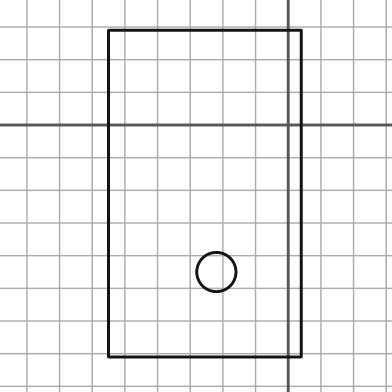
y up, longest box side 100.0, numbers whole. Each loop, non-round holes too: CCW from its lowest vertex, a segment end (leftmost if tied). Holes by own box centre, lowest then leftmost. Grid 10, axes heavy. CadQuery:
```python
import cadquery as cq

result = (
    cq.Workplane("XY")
    .moveTo(-55.0, -71.0)
    .lineTo(4.0, -71.0)
    .lineTo(4.0, 29.0)
    .lineTo(-55.0, 29.0)
    .close()
    .moveTo(-22.0, -45.0)
    .circle(6.0)
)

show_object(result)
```